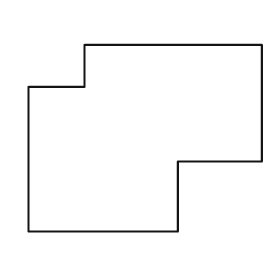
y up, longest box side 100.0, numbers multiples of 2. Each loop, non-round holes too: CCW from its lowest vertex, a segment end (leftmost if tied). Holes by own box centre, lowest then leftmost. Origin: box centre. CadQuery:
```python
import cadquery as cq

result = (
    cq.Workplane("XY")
    .moveTo(-50.0, -40.0)
    .lineTo(14.0, -40.0)
    .lineTo(14.0, -10.0)
    .lineTo(50.0, -10.0)
    .lineTo(50.0, 40.0)
    .lineTo(-26.0, 40.0)
    .lineTo(-26.0, 22.0)
    .lineTo(-50.0, 22.0)
    .close()
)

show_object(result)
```